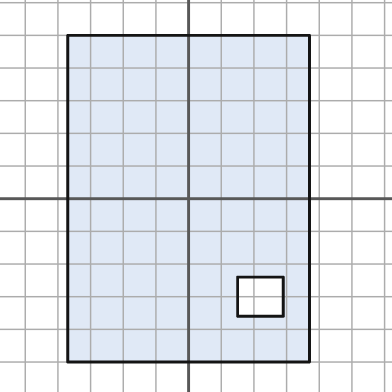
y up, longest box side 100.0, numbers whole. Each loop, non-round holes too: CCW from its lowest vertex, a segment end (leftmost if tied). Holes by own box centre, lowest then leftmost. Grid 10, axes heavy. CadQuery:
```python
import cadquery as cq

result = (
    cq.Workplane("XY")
    .moveTo(-37.0, -50.0)
    .lineTo(37.0, -50.0)
    .lineTo(37.0, 50.0)
    .lineTo(-37.0, 50.0)
    .close()
    .moveTo(15.0, -36.0)
    .lineTo(29.0, -36.0)
    .lineTo(29.0, -24.0)
    .lineTo(15.0, -24.0)
    .close()
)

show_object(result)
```